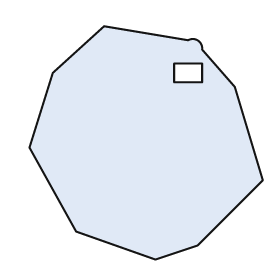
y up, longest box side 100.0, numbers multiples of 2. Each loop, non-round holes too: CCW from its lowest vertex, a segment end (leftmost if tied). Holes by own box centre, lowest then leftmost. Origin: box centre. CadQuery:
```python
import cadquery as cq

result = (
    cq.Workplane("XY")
    .moveTo(4.0, -50.0)
    .lineTo(22.0, -44.0)
    .lineTo(50.0, -16.0)
    .lineTo(38.0, 24.0)
    .lineTo(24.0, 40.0)
    .threePointArc((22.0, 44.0), (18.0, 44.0))
    .lineTo(-18.0, 50.0)
    .lineTo(-40.0, 30.0)
    .lineTo(-50.0, -2.0)
    .lineTo(-30.0, -38.0)
    .close()
    .moveTo(12.0, 26.0)
    .lineTo(24.0, 26.0)
    .lineTo(24.0, 34.0)
    .lineTo(12.0, 34.0)
    .close()
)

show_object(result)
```